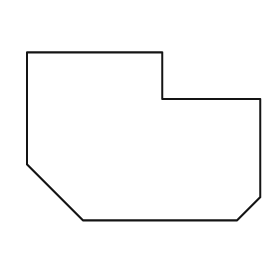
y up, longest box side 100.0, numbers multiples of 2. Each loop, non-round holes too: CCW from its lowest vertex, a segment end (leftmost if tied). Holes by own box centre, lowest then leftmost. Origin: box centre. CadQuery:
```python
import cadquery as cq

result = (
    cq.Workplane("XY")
    .moveTo(-26.0, -36.0)
    .lineTo(40.0, -36.0)
    .lineTo(50.0, -26.0)
    .lineTo(50.0, 16.0)
    .lineTo(8.0, 16.0)
    .lineTo(8.0, 36.0)
    .lineTo(-50.0, 36.0)
    .lineTo(-50.0, -12.0)
    .close()
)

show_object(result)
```